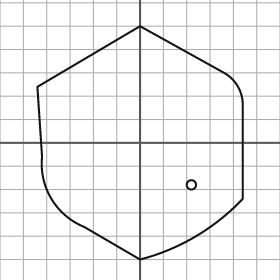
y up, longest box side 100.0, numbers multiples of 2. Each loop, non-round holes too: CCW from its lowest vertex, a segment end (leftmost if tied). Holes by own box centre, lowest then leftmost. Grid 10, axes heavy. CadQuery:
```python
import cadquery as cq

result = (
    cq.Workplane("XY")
    .moveTo(0.0, -50.0)
    .threePointArc((24.0, -40.0), (44.0, -24.0))
    .lineTo(44.0, 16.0)
    .threePointArc((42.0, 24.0), (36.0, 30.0))
    .lineTo(0.0, 50.0)
    .lineTo(-44.0, 24.0)
    .lineTo(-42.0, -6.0)
    .threePointArc((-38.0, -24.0), (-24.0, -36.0))
    .close()
    .moveTo(22.0, -18.0)
    .circle(2.0)
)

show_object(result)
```